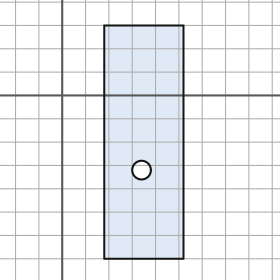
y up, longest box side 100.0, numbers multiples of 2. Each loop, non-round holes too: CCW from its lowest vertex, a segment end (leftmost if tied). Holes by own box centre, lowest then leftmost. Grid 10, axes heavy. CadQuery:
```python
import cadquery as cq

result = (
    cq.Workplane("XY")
    .moveTo(18.0, -70.0)
    .lineTo(52.0, -70.0)
    .lineTo(52.0, 30.0)
    .lineTo(18.0, 30.0)
    .close()
    .moveTo(34.0, -32.0)
    .circle(4.0)
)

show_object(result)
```